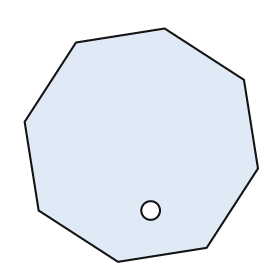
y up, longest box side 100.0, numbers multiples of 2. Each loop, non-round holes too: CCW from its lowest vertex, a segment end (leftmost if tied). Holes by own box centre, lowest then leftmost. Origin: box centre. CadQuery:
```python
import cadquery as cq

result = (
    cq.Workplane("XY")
    .moveTo(-10.0, -50.0)
    .lineTo(28.0, -44.0)
    .lineTo(50.0, -10.0)
    .lineTo(44.0, 28.0)
    .lineTo(10.0, 50.0)
    .lineTo(-28.0, 44.0)
    .lineTo(-50.0, 10.0)
    .lineTo(-44.0, -28.0)
    .close()
    .moveTo(4.0, -28.0)
    .circle(4.0)
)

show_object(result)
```